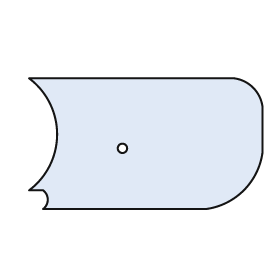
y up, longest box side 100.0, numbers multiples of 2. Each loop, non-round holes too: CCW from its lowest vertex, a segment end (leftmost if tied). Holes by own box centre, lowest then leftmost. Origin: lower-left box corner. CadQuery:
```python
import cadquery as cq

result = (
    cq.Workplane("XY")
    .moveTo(6.0, 0.0)
    .lineTo(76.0, 0.0)
    .threePointArc((92.0, 8.0), (100.0, 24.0))
    .lineTo(100.0, 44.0)
    .threePointArc((96.0, 52.0), (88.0, 56.0))
    .lineTo(0.0, 56.0)
    .threePointArc((12.0, 32.0), (0.0, 8.0))
    .lineTo(6.0, 8.0)
    .threePointArc((8.0, 4.0), (6.0, 0.0))
    .close()
    .moveTo(40.0, 26.0)
    .circle(2.0)
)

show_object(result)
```